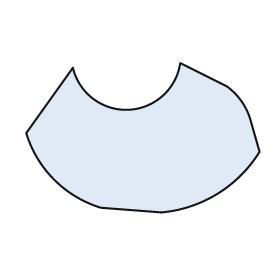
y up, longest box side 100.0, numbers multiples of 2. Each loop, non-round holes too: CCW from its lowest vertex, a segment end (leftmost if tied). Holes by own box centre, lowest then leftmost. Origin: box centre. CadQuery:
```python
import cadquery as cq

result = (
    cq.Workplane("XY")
    .moveTo(8.0, -32.0)
    .threePointArc((32.0, -24.0), (50.0, -6.0))
    .lineTo(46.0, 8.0)
    .threePointArc((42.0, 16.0), (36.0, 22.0))
    .lineTo(16.0, 32.0)
    .threePointArc((-6.0, 12.0), (-30.0, 30.0))
    .lineTo(-50.0, 2.0)
    .threePointArc((-38.0, -18.0), (-18.0, -30.0))
    .close()
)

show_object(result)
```